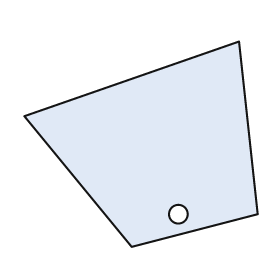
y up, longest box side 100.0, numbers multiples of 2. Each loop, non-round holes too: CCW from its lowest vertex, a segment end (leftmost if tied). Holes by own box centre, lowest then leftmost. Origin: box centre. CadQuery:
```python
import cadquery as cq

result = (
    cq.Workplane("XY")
    .moveTo(-4.0, -44.0)
    .lineTo(50.0, -30.0)
    .lineTo(42.0, 44.0)
    .lineTo(-50.0, 12.0)
    .close()
    .moveTo(16.0, -30.0)
    .circle(4.0)
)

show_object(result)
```